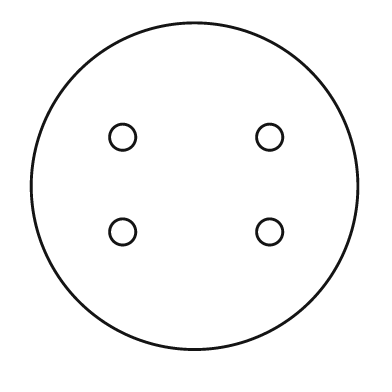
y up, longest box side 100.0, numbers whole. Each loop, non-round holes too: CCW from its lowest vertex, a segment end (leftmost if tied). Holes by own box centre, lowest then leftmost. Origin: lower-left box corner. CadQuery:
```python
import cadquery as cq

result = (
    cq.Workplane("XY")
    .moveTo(50.0, 50.0)
    .circle(50.0)
    .moveTo(28.0, 36.0)
    .circle(4.0)
    .moveTo(73.0, 36.0)
    .circle(4.0)
    .moveTo(28.0, 65.0)
    .circle(4.0)
    .moveTo(73.0, 65.0)
    .circle(4.0)
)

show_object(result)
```